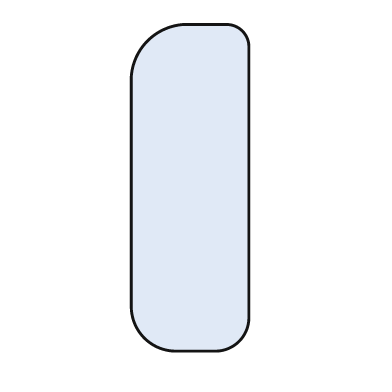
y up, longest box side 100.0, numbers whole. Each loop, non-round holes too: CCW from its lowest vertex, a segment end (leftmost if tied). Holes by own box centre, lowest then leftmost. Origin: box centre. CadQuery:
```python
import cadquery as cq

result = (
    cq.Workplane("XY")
    .moveTo(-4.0, -50.0)
    .lineTo(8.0, -50.0)
    .threePointArc((15.0, -47.0), (18.0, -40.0))
    .lineTo(18.0, 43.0)
    .threePointArc((16.0, 48.0), (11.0, 50.0))
    .lineTo(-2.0, 50.0)
    .threePointArc((-13.0, 45.0), (-18.0, 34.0))
    .lineTo(-18.0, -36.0)
    .threePointArc((-14.0, -46.0), (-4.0, -50.0))
    .close()
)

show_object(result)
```